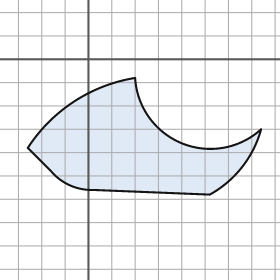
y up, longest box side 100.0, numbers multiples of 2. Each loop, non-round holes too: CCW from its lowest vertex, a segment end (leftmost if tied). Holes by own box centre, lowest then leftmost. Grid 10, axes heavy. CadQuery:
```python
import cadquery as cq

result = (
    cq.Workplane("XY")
    .moveTo(52.0, -58.0)
    .threePointArc((66.0, -46.0), (74.0, -30.0))
    .threePointArc((40.0, -36.0), (20.0, -8.0))
    .threePointArc((-6.0, -18.0), (-26.0, -38.0))
    .lineTo(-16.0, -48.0)
    .threePointArc((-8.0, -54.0), (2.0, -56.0))
    .close()
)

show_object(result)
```